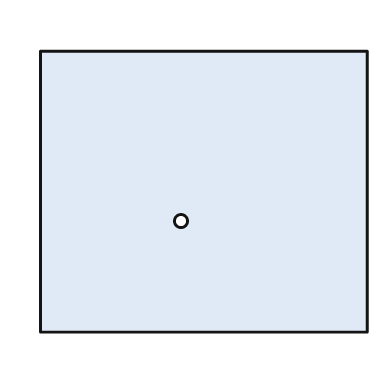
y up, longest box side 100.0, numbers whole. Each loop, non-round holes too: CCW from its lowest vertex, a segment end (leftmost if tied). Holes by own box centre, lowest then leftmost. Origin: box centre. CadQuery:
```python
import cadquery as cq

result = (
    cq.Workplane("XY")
    .moveTo(-50.0, -43.0)
    .lineTo(50.0, -43.0)
    .lineTo(50.0, 43.0)
    .lineTo(-50.0, 43.0)
    .close()
    .moveTo(-7.0, -9.0)
    .circle(2.0)
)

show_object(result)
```